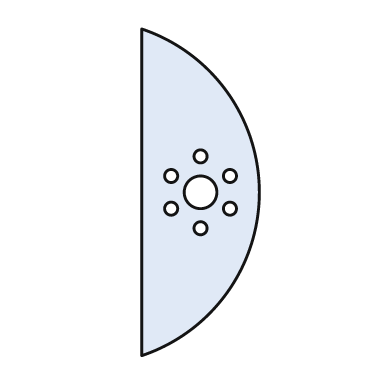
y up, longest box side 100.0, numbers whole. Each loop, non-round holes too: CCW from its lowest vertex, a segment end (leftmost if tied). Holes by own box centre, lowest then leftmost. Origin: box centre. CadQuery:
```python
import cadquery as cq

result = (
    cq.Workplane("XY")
    .moveTo(-18.0, -50.0)
    .threePointArc((18.0, 0.0), (-18.0, 50.0))
    .close()
    .moveTo(0.0, -11.0)
    .circle(2.0)
    .moveTo(-9.0, -5.0)
    .circle(2.0)
    .moveTo(9.0, -5.0)
    .circle(2.0)
    .moveTo(0.0, 0.0)
    .circle(5.0)
    .moveTo(-9.0, 5.0)
    .circle(2.0)
    .moveTo(9.0, 5.0)
    .circle(2.0)
    .moveTo(0.0, 11.0)
    .circle(2.0)
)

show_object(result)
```